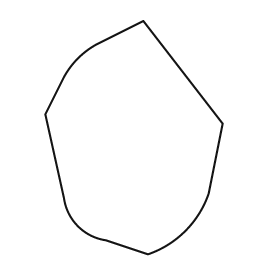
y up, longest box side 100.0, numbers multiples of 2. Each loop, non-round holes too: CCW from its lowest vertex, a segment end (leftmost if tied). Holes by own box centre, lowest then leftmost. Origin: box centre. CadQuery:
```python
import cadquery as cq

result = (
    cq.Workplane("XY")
    .moveTo(6.0, -50.0)
    .threePointArc((22.0, -40.0), (32.0, -24.0))
    .lineTo(38.0, 6.0)
    .lineTo(4.0, 50.0)
    .lineTo(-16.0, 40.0)
    .threePointArc((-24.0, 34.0), (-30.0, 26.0))
    .lineTo(-38.0, 10.0)
    .lineTo(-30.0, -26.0)
    .threePointArc((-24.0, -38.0), (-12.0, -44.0))
    .close()
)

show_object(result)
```